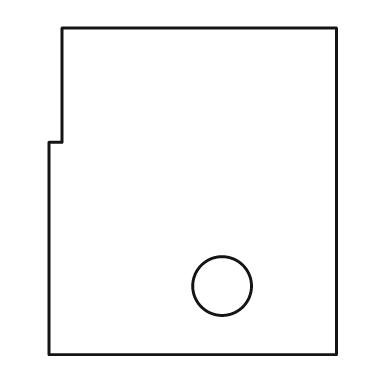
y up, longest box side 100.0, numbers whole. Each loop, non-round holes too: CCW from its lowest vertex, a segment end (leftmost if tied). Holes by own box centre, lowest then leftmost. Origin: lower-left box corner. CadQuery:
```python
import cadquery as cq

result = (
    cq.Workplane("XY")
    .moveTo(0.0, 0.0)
    .lineTo(88.0, 0.0)
    .lineTo(88.0, 100.0)
    .lineTo(4.0, 100.0)
    .lineTo(4.0, 65.0)
    .lineTo(0.0, 65.0)
    .close()
    .moveTo(53.0, 21.0)
    .circle(9.0)
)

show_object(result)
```